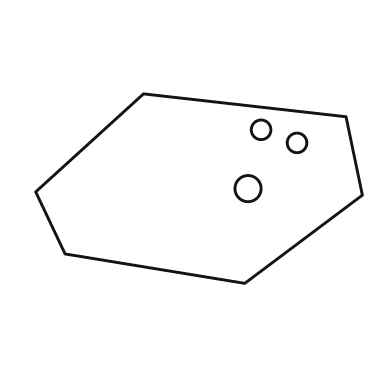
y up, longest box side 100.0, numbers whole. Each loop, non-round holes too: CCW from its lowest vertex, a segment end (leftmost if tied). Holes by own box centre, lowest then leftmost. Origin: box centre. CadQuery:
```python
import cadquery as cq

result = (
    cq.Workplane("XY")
    .moveTo(14.0, -29.0)
    .lineTo(50.0, -2.0)
    .lineTo(45.0, 22.0)
    .lineTo(-17.0, 29.0)
    .lineTo(-50.0, -1.0)
    .lineTo(-41.0, -20.0)
    .close()
    .moveTo(15.0, 0.0)
    .circle(4.0)
    .moveTo(30.0, 14.0)
    .circle(3.0)
    .moveTo(19.0, 18.0)
    .circle(3.0)
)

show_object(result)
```